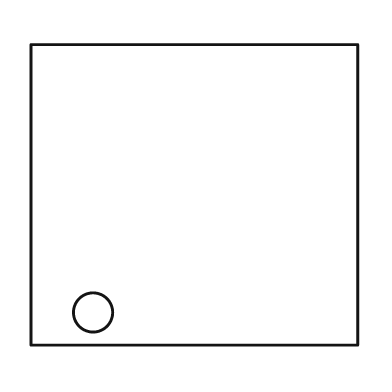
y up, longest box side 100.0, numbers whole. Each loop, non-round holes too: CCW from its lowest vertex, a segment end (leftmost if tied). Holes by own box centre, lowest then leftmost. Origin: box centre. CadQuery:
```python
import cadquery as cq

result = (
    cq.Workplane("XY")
    .moveTo(-50.0, -46.0)
    .lineTo(50.0, -46.0)
    .lineTo(50.0, 46.0)
    .lineTo(-50.0, 46.0)
    .close()
    .moveTo(-31.0, -36.0)
    .circle(6.0)
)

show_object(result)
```